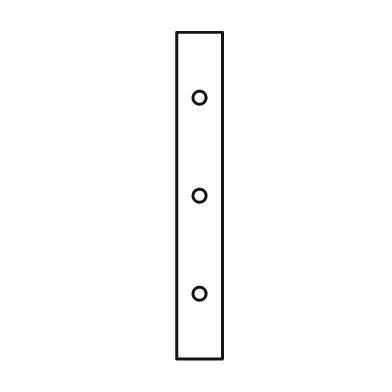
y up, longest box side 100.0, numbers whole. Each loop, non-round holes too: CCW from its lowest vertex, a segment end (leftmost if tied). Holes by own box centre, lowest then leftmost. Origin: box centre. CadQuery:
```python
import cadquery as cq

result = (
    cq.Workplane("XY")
    .moveTo(-7.0, -50.0)
    .lineTo(7.0, -50.0)
    .lineTo(7.0, 50.0)
    .lineTo(-7.0, 50.0)
    .close()
    .moveTo(0.0, -30.0)
    .circle(2.0)
    .moveTo(0.0, 0.0)
    .circle(2.0)
    .moveTo(0.0, 30.0)
    .circle(2.0)
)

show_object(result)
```